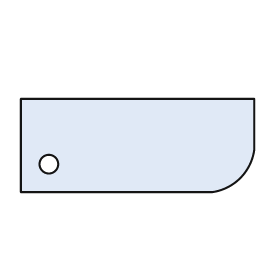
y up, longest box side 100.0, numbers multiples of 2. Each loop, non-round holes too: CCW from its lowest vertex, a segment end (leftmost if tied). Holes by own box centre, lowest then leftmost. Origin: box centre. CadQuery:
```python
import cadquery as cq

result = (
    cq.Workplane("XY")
    .moveTo(-50.0, -20.0)
    .lineTo(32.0, -20.0)
    .threePointArc((44.0, -14.0), (50.0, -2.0))
    .lineTo(50.0, 20.0)
    .lineTo(-50.0, 20.0)
    .close()
    .moveTo(-38.0, -8.0)
    .circle(4.0)
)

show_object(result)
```